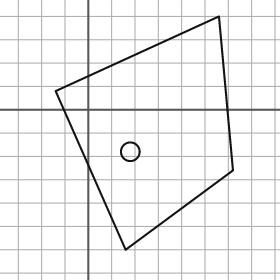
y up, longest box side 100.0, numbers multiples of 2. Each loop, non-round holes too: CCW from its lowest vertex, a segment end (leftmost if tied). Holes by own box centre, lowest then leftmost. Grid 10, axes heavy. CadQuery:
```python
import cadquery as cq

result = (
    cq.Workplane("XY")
    .moveTo(16.0, -60.0)
    .lineTo(62.0, -26.0)
    .lineTo(56.0, 40.0)
    .lineTo(-14.0, 8.0)
    .close()
    .moveTo(18.0, -18.0)
    .circle(4.0)
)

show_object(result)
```